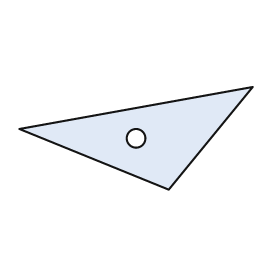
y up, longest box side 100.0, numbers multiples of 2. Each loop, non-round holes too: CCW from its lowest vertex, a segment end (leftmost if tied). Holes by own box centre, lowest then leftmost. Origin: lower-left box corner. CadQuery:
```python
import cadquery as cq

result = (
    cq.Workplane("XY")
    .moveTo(64.0, 0.0)
    .lineTo(100.0, 44.0)
    .lineTo(0.0, 26.0)
    .close()
    .moveTo(50.0, 22.0)
    .circle(4.0)
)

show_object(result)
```